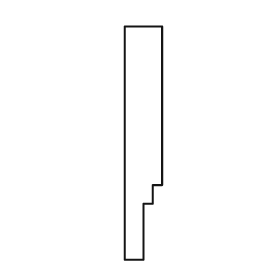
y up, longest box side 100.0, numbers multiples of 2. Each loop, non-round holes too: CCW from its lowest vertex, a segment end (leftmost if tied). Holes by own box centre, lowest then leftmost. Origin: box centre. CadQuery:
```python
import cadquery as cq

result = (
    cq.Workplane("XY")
    .moveTo(-8.0, -50.0)
    .lineTo(0.0, -50.0)
    .lineTo(0.0, -26.0)
    .lineTo(4.0, -26.0)
    .lineTo(4.0, -18.0)
    .lineTo(8.0, -18.0)
    .lineTo(8.0, 50.0)
    .lineTo(-8.0, 50.0)
    .close()
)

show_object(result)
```